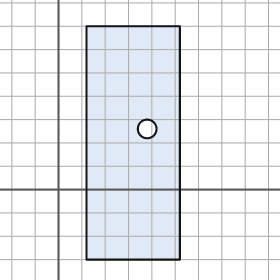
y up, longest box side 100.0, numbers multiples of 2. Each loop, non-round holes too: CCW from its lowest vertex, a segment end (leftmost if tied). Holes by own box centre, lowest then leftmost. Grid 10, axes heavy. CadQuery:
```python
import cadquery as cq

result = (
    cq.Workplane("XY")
    .moveTo(12.0, -30.0)
    .lineTo(52.0, -30.0)
    .lineTo(52.0, 70.0)
    .lineTo(12.0, 70.0)
    .close()
    .moveTo(38.0, 26.0)
    .circle(4.0)
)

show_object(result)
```